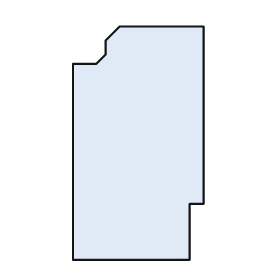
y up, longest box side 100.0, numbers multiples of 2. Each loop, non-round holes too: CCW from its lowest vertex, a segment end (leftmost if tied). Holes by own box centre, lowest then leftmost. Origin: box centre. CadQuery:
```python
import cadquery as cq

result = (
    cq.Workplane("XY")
    .moveTo(-28.0, -50.0)
    .lineTo(22.0, -50.0)
    .lineTo(22.0, -26.0)
    .lineTo(28.0, -26.0)
    .lineTo(28.0, 50.0)
    .lineTo(-8.0, 50.0)
    .lineTo(-14.0, 44.0)
    .lineTo(-14.0, 38.0)
    .lineTo(-18.0, 34.0)
    .lineTo(-28.0, 34.0)
    .close()
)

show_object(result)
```